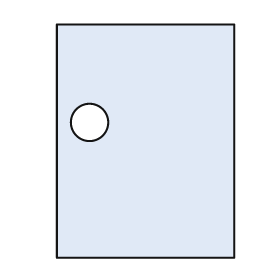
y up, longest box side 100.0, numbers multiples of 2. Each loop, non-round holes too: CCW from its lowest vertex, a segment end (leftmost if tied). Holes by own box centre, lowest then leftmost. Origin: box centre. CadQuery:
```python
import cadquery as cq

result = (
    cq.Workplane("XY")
    .moveTo(-38.0, -50.0)
    .lineTo(38.0, -50.0)
    .lineTo(38.0, 50.0)
    .lineTo(-38.0, 50.0)
    .close()
    .moveTo(-24.0, 8.0)
    .circle(8.0)
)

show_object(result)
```